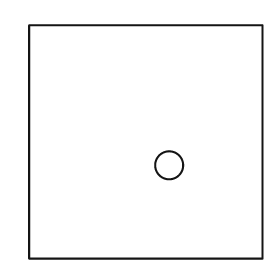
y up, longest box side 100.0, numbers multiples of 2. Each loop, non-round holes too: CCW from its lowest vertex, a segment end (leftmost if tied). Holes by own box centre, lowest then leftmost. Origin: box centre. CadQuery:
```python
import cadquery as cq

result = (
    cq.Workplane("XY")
    .moveTo(-50.0, -50.0)
    .lineTo(50.0, -50.0)
    .lineTo(50.0, 50.0)
    .lineTo(-50.0, 50.0)
    .close()
    .moveTo(10.0, -10.0)
    .circle(6.0)
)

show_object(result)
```